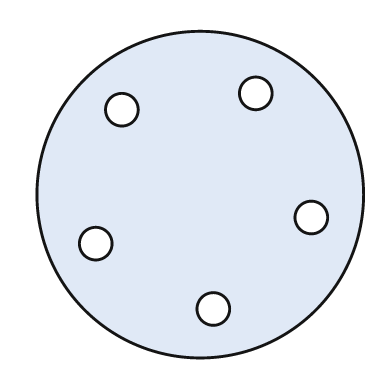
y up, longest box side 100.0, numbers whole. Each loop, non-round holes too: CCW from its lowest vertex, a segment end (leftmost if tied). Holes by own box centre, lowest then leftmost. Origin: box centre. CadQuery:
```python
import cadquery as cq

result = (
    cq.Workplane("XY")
    .moveTo(0.0, 0.0)
    .circle(50.0)
    .moveTo(4.0, -35.0)
    .circle(5.0)
    .moveTo(-32.0, -15.0)
    .circle(5.0)
    .moveTo(34.0, -7.0)
    .circle(5.0)
    .moveTo(-24.0, 26.0)
    .circle(5.0)
    .moveTo(17.0, 31.0)
    .circle(5.0)
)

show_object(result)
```